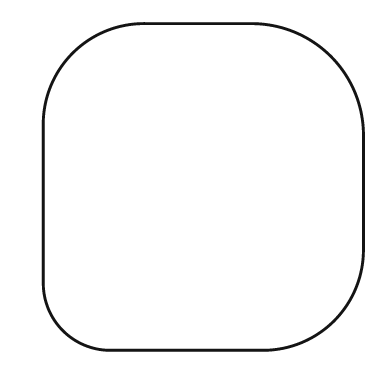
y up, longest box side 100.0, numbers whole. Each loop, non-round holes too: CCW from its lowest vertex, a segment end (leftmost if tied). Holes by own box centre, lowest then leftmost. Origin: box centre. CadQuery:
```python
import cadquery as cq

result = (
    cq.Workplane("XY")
    .moveTo(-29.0, -50.0)
    .lineTo(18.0, -50.0)
    .threePointArc((40.0, -41.0), (49.0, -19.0))
    .lineTo(49.0, 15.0)
    .threePointArc((39.0, 40.0), (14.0, 50.0))
    .lineTo(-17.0, 50.0)
    .threePointArc((-40.0, 41.0), (-49.0, 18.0))
    .lineTo(-49.0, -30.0)
    .threePointArc((-43.0, -44.0), (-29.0, -50.0))
    .close()
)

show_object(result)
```